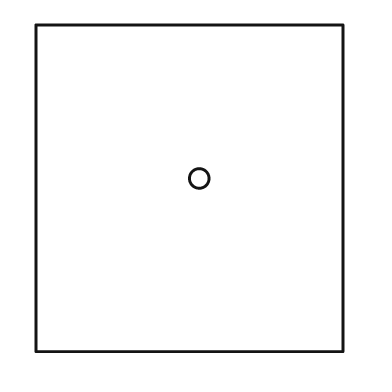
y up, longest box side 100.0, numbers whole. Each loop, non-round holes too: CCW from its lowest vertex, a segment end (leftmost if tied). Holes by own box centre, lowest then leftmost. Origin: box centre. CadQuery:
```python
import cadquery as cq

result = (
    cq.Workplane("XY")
    .moveTo(-47.0, -50.0)
    .lineTo(47.0, -50.0)
    .lineTo(47.0, 50.0)
    .lineTo(-47.0, 50.0)
    .close()
    .moveTo(3.0, 3.0)
    .circle(3.0)
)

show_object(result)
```